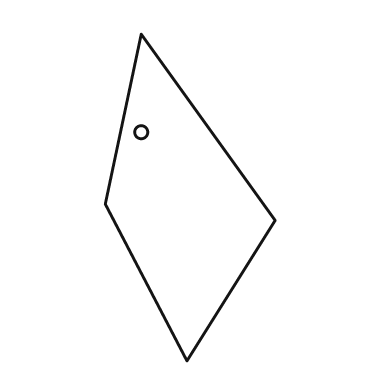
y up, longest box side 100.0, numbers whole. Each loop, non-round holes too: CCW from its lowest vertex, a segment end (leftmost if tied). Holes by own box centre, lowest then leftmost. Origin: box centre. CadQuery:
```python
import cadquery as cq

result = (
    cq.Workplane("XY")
    .moveTo(-1.0, -50.0)
    .lineTo(26.0, -7.0)
    .lineTo(-15.0, 50.0)
    .lineTo(-26.0, -2.0)
    .close()
    .moveTo(-15.0, 20.0)
    .circle(2.0)
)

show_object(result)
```